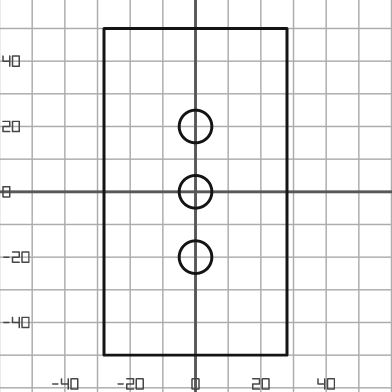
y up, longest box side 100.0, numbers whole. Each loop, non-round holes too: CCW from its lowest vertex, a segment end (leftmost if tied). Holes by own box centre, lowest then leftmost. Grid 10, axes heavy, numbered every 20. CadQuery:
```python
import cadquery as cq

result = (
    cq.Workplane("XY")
    .moveTo(-28.0, -50.0)
    .lineTo(28.0, -50.0)
    .lineTo(28.0, 50.0)
    .lineTo(-28.0, 50.0)
    .close()
    .moveTo(0.0, -20.0)
    .circle(5.0)
    .moveTo(0.0, 0.0)
    .circle(5.0)
    .moveTo(0.0, 20.0)
    .circle(5.0)
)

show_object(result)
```